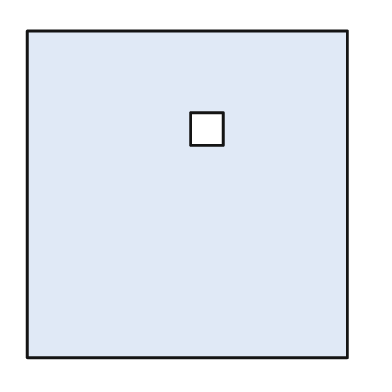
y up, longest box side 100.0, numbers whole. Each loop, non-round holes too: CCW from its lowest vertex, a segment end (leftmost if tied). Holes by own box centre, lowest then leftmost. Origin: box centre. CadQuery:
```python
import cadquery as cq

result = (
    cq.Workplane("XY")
    .moveTo(-49.0, -50.0)
    .lineTo(49.0, -50.0)
    .lineTo(49.0, 50.0)
    .lineTo(-49.0, 50.0)
    .close()
    .moveTo(1.0, 15.0)
    .lineTo(11.0, 15.0)
    .lineTo(11.0, 25.0)
    .lineTo(1.0, 25.0)
    .close()
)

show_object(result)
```